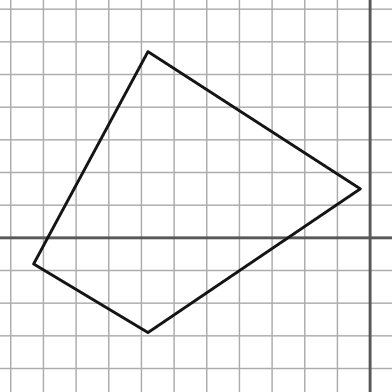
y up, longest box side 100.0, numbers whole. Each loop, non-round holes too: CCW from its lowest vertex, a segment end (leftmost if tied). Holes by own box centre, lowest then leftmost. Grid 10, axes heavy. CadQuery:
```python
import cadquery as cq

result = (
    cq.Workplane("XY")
    .moveTo(-68.0, -29.0)
    .lineTo(-3.0, 15.0)
    .lineTo(-68.0, 57.0)
    .lineTo(-103.0, -8.0)
    .close()
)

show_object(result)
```